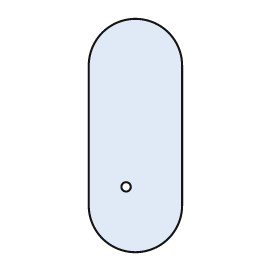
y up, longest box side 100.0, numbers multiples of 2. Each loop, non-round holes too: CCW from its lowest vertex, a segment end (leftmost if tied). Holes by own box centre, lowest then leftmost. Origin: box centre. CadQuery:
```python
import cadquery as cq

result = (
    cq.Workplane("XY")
    .moveTo(-20.0, -30.0)
    .threePointArc((0.0, -50.0), (20.0, -30.0))
    .lineTo(20.0, 30.0)
    .threePointArc((0.0, 50.0), (-20.0, 30.0))
    .close()
    .moveTo(-4.0, -22.0)
    .circle(2.0)
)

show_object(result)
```